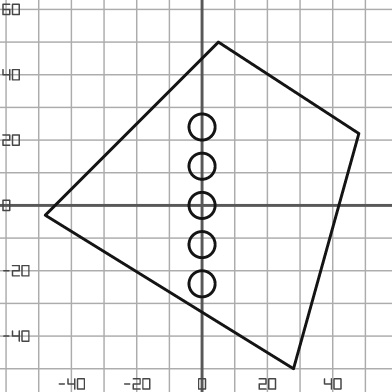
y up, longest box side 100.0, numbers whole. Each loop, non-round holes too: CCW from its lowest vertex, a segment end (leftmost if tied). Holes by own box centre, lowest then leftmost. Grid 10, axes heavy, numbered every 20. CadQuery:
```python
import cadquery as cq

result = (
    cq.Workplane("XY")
    .moveTo(28.0, -50.0)
    .lineTo(48.0, 22.0)
    .lineTo(5.0, 50.0)
    .lineTo(-48.0, -3.0)
    .close()
    .moveTo(0.0, -24.0)
    .circle(4.0)
    .moveTo(0.0, -12.0)
    .circle(4.0)
    .moveTo(0.0, 0.0)
    .circle(4.0)
    .moveTo(0.0, 12.0)
    .circle(4.0)
    .moveTo(0.0, 24.0)
    .circle(4.0)
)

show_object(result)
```